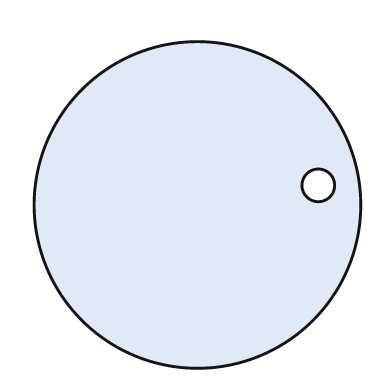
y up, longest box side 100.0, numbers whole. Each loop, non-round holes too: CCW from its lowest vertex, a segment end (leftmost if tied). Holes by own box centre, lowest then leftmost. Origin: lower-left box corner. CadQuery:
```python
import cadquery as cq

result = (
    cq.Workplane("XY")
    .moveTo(50.0, 50.0)
    .circle(50.0)
    .moveTo(87.0, 56.0)
    .circle(5.0)
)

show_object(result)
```